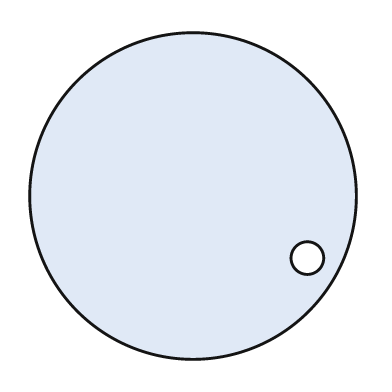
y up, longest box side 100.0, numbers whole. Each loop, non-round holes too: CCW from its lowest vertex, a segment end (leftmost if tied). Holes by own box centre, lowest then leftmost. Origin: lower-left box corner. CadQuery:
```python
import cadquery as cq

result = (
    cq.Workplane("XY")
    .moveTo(50.0, 50.0)
    .circle(50.0)
    .moveTo(85.0, 31.0)
    .circle(5.0)
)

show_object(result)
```